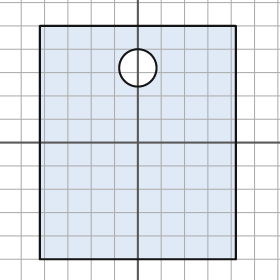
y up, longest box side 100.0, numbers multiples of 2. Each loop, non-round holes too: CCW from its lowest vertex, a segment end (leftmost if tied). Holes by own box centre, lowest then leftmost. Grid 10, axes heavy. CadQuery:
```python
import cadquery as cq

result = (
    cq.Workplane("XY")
    .moveTo(-42.0, -50.0)
    .lineTo(42.0, -50.0)
    .lineTo(42.0, 50.0)
    .lineTo(-42.0, 50.0)
    .close()
    .moveTo(0.0, 32.0)
    .circle(8.0)
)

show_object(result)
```